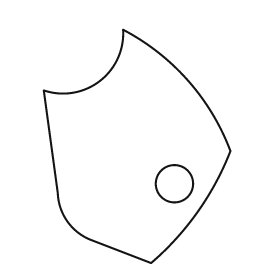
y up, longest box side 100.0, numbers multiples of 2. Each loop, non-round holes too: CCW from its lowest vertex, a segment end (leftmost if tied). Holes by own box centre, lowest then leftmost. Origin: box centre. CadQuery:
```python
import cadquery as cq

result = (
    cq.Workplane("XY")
    .moveTo(6.0, -50.0)
    .threePointArc((26.0, -28.0), (40.0, -2.0))
    .threePointArc((22.0, 28.0), (-6.0, 50.0))
    .threePointArc((-16.0, 28.0), (-40.0, 24.0))
    .lineTo(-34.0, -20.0)
    .threePointArc((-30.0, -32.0), (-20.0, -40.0))
    .close()
    .moveTo(16.0, -16.0)
    .circle(8.0)
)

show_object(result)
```